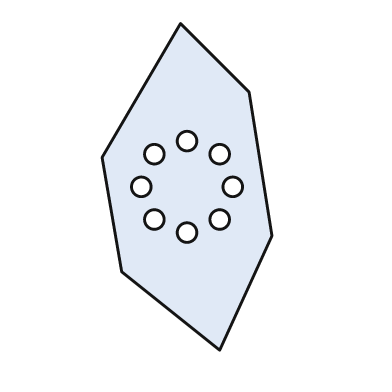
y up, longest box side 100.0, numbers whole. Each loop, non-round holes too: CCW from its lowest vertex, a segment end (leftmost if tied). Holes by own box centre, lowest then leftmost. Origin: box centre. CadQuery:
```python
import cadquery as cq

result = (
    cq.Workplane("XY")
    .moveTo(10.0, -50.0)
    .lineTo(26.0, -15.0)
    .lineTo(19.0, 29.0)
    .lineTo(-2.0, 50.0)
    .lineTo(-26.0, 9.0)
    .lineTo(-20.0, -26.0)
    .close()
    .moveTo(0.0, -14.0)
    .circle(3.0)
    .moveTo(-10.0, -10.0)
    .circle(3.0)
    .moveTo(10.0, -10.0)
    .circle(3.0)
    .moveTo(-14.0, 0.0)
    .circle(3.0)
    .moveTo(14.0, 0.0)
    .circle(3.0)
    .moveTo(-10.0, 10.0)
    .circle(3.0)
    .moveTo(10.0, 10.0)
    .circle(3.0)
    .moveTo(0.0, 14.0)
    .circle(3.0)
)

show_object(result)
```